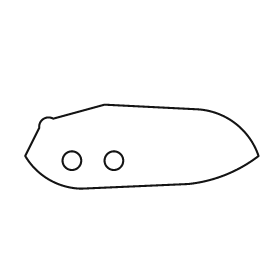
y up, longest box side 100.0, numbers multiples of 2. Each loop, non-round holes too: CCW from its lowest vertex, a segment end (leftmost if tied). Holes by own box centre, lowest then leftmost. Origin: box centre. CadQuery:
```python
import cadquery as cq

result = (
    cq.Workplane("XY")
    .moveTo(-26.0, -18.0)
    .lineTo(20.0, -16.0)
    .threePointArc((36.0, -12.0), (50.0, -4.0))
    .threePointArc((40.0, 10.0), (24.0, 16.0))
    .lineTo(-16.0, 18.0)
    .lineTo(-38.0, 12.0)
    .threePointArc((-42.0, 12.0), (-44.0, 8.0))
    .lineTo(-50.0, -4.0)
    .threePointArc((-40.0, -14.0), (-26.0, -18.0))
    .close()
    .moveTo(-30.0, -6.0)
    .circle(4.0)
    .moveTo(-12.0, -6.0)
    .circle(4.0)
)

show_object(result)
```